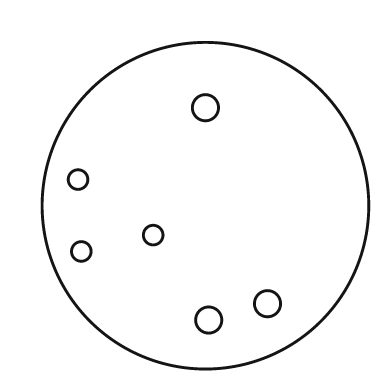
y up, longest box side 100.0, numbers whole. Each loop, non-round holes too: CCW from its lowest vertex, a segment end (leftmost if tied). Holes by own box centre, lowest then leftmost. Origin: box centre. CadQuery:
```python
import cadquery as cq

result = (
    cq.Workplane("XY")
    .moveTo(0.0, 0.0)
    .circle(50.0)
    .moveTo(1.0, -35.0)
    .circle(4.0)
    .moveTo(19.0, -30.0)
    .circle(4.0)
    .moveTo(-38.0, -14.0)
    .circle(3.0)
    .moveTo(-16.0, -9.0)
    .circle(3.0)
    .moveTo(-39.0, 8.0)
    .circle(3.0)
    .moveTo(0.0, 30.0)
    .circle(4.0)
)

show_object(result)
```